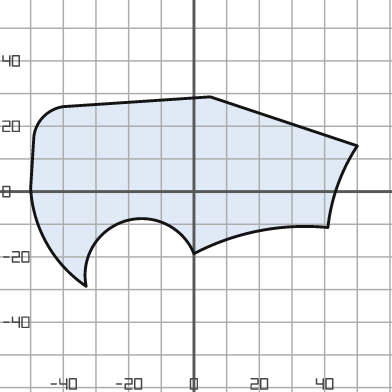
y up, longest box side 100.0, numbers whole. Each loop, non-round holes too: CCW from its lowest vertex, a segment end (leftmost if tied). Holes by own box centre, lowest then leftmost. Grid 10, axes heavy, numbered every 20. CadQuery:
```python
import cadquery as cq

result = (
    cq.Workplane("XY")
    .moveTo(-33.0, -29.0)
    .threePointArc((-21.0, -9.0), (0.0, -19.0))
    .threePointArc((20.0, -12.0), (41.0, -11.0))
    .threePointArc((44.0, 2.0), (50.0, 14.0))
    .lineTo(5.0, 29.0)
    .lineTo(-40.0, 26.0)
    .threePointArc((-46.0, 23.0), (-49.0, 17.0))
    .lineTo(-50.0, 1.0)
    .threePointArc((-45.0, -16.0), (-33.0, -29.0))
    .close()
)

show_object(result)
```